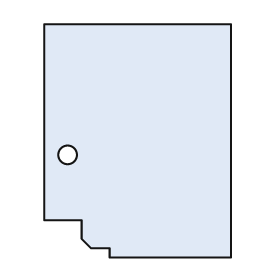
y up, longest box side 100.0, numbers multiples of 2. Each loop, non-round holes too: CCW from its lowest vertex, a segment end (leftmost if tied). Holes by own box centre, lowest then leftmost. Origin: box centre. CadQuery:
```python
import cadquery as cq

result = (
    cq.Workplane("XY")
    .moveTo(-12.0, -50.0)
    .lineTo(40.0, -50.0)
    .lineTo(40.0, 50.0)
    .lineTo(-40.0, 50.0)
    .lineTo(-40.0, -34.0)
    .lineTo(-24.0, -34.0)
    .lineTo(-24.0, -42.0)
    .lineTo(-20.0, -46.0)
    .lineTo(-12.0, -46.0)
    .close()
    .moveTo(-30.0, -6.0)
    .circle(4.0)
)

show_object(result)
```